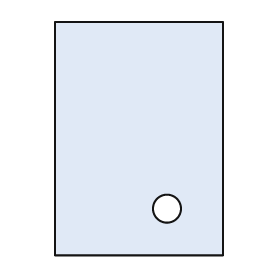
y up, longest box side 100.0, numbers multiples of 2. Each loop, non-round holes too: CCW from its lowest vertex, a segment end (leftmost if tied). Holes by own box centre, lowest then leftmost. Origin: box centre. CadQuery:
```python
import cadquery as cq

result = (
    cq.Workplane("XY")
    .moveTo(-36.0, -50.0)
    .lineTo(36.0, -50.0)
    .lineTo(36.0, 50.0)
    .lineTo(-36.0, 50.0)
    .close()
    .moveTo(12.0, -30.0)
    .circle(6.0)
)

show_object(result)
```